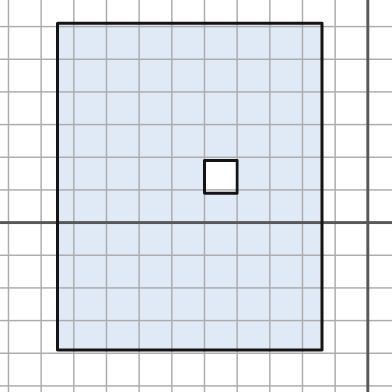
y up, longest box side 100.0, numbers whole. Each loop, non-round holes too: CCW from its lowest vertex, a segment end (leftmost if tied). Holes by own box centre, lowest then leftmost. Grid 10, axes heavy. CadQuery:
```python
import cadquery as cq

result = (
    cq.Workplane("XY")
    .moveTo(-95.0, -39.0)
    .lineTo(-14.0, -39.0)
    .lineTo(-14.0, 61.0)
    .lineTo(-95.0, 61.0)
    .close()
    .moveTo(-50.0, 9.0)
    .lineTo(-40.0, 9.0)
    .lineTo(-40.0, 19.0)
    .lineTo(-50.0, 19.0)
    .close()
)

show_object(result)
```